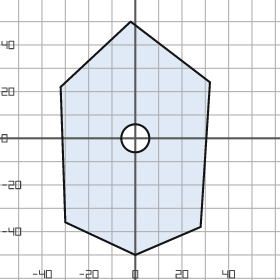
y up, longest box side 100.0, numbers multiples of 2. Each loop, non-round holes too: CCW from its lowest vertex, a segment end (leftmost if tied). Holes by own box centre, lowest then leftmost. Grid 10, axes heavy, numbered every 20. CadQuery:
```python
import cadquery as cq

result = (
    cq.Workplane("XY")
    .moveTo(0.0, -50.0)
    .lineTo(28.0, -38.0)
    .lineTo(32.0, 24.0)
    .lineTo(-2.0, 50.0)
    .lineTo(-32.0, 22.0)
    .lineTo(-30.0, -36.0)
    .close()
    .moveTo(0.0, 0.0)
    .circle(6.0)
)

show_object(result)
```